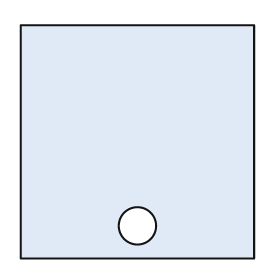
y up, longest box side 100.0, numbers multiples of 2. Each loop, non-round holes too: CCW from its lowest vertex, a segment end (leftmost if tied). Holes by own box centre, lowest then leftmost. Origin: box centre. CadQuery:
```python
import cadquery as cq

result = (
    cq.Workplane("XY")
    .moveTo(-50.0, -50.0)
    .lineTo(50.0, -50.0)
    .lineTo(50.0, 50.0)
    .lineTo(-50.0, 50.0)
    .close()
    .moveTo(0.0, -36.0)
    .circle(8.0)
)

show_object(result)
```